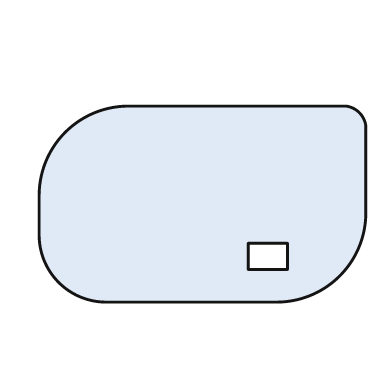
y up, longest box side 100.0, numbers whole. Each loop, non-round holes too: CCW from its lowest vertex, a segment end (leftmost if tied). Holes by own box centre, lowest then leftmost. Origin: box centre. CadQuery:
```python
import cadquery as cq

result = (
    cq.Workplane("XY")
    .moveTo(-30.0, -30.0)
    .lineTo(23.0, -30.0)
    .threePointArc((42.0, -22.0), (50.0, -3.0))
    .lineTo(50.0, 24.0)
    .threePointArc((48.0, 28.0), (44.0, 30.0))
    .lineTo(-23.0, 30.0)
    .threePointArc((-42.0, 22.0), (-50.0, 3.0))
    .lineTo(-50.0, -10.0)
    .threePointArc((-44.0, -24.0), (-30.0, -30.0))
    .close()
    .moveTo(14.0, -20.0)
    .lineTo(26.0, -20.0)
    .lineTo(26.0, -12.0)
    .lineTo(14.0, -12.0)
    .close()
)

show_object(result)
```